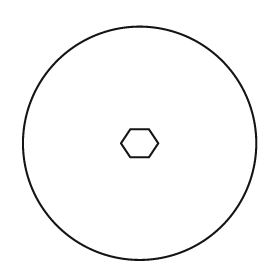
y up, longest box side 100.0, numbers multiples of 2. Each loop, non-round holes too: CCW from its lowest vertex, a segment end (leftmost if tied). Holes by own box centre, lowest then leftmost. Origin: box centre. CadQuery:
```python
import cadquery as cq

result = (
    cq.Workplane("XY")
    .moveTo(0.0, 0.0)
    .circle(50.0)
    .moveTo(-4.0, -6.0)
    .lineTo(4.0, -6.0)
    .lineTo(8.0, 0.0)
    .lineTo(4.0, 6.0)
    .lineTo(-4.0, 6.0)
    .lineTo(-8.0, 0.0)
    .close()
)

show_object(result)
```